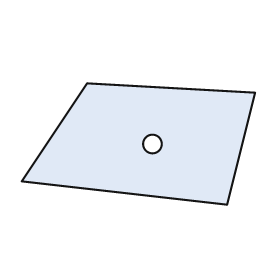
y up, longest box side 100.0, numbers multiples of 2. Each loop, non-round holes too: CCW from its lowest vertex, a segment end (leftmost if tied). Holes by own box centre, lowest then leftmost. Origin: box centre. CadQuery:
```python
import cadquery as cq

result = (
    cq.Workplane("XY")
    .moveTo(38.0, -26.0)
    .lineTo(50.0, 22.0)
    .lineTo(-22.0, 26.0)
    .lineTo(-50.0, -16.0)
    .close()
    .moveTo(6.0, 0.0)
    .circle(4.0)
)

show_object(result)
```